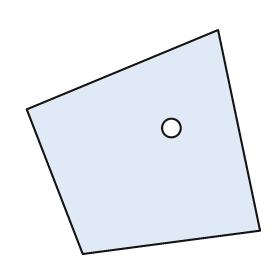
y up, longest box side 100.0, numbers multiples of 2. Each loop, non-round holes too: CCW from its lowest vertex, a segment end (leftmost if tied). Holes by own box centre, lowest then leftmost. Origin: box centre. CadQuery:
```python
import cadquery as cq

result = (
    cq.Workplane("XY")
    .moveTo(-26.0, -48.0)
    .lineTo(50.0, -38.0)
    .lineTo(32.0, 48.0)
    .lineTo(-50.0, 14.0)
    .close()
    .moveTo(12.0, 6.0)
    .circle(4.0)
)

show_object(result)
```